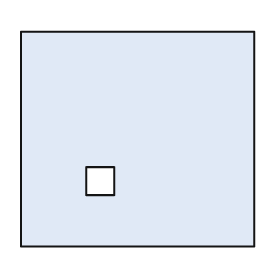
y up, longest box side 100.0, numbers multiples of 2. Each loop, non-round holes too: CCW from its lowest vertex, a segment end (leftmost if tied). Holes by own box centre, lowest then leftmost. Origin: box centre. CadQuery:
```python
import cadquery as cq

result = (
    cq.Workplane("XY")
    .moveTo(-50.0, -46.0)
    .lineTo(50.0, -46.0)
    .lineTo(50.0, 46.0)
    .lineTo(-50.0, 46.0)
    .close()
    .moveTo(-22.0, -24.0)
    .lineTo(-10.0, -24.0)
    .lineTo(-10.0, -12.0)
    .lineTo(-22.0, -12.0)
    .close()
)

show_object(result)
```